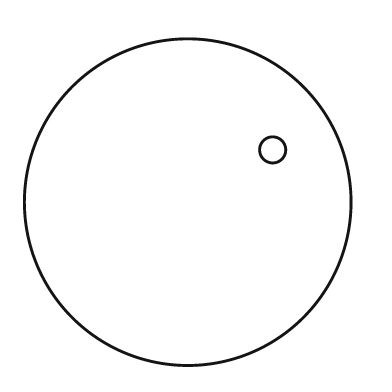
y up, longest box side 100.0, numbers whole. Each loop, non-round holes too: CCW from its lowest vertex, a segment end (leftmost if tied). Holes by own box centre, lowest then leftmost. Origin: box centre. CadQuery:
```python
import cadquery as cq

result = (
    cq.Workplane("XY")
    .moveTo(0.0, 0.0)
    .circle(50.0)
    .moveTo(26.0, 16.0)
    .circle(4.0)
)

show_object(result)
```